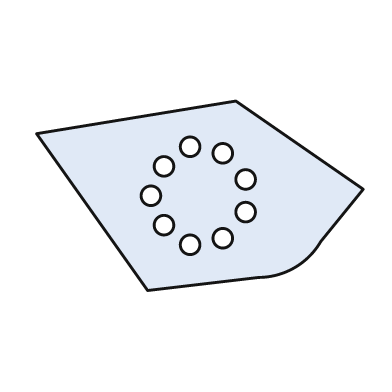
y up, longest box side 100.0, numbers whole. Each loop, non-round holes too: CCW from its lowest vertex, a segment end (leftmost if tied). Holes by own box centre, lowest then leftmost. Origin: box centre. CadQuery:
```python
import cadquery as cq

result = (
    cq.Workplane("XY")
    .moveTo(-16.0, -29.0)
    .lineTo(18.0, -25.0)
    .threePointArc((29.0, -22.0), (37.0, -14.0))
    .lineTo(50.0, 2.0)
    .lineTo(11.0, 29.0)
    .lineTo(-50.0, 19.0)
    .close()
    .moveTo(-3.0, -15.0)
    .circle(3.0)
    .moveTo(7.0, -13.0)
    .circle(3.0)
    .moveTo(-11.0, -9.0)
    .circle(3.0)
    .moveTo(14.0, -5.0)
    .circle(3.0)
    .moveTo(-15.0, 0.0)
    .circle(3.0)
    .moveTo(14.0, 5.0)
    .circle(3.0)
    .moveTo(-11.0, 9.0)
    .circle(3.0)
    .moveTo(7.0, 13.0)
    .circle(3.0)
    .moveTo(-3.0, 15.0)
    .circle(3.0)
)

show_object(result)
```